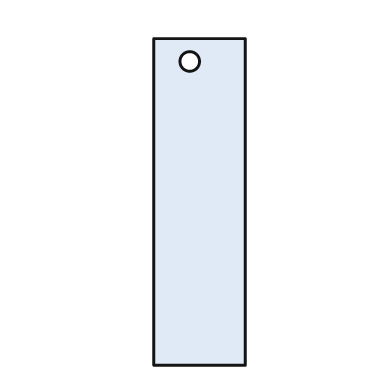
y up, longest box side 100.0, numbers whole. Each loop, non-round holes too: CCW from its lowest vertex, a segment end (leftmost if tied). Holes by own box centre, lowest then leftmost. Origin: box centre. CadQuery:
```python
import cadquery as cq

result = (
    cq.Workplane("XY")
    .moveTo(-14.0, -50.0)
    .lineTo(14.0, -50.0)
    .lineTo(14.0, 50.0)
    .lineTo(-14.0, 50.0)
    .close()
    .moveTo(-3.0, 43.0)
    .circle(3.0)
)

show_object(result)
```